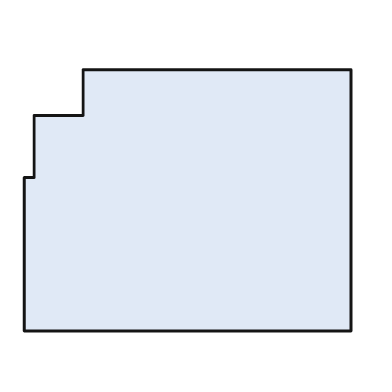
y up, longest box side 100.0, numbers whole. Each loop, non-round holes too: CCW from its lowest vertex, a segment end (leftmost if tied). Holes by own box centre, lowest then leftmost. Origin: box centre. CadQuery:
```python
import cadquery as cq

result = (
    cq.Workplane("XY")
    .moveTo(-50.0, -40.0)
    .lineTo(50.0, -40.0)
    .lineTo(50.0, 40.0)
    .lineTo(-32.0, 40.0)
    .lineTo(-32.0, 26.0)
    .lineTo(-47.0, 26.0)
    .lineTo(-47.0, 7.0)
    .lineTo(-50.0, 7.0)
    .close()
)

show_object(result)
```